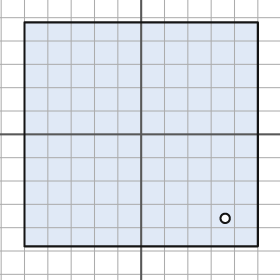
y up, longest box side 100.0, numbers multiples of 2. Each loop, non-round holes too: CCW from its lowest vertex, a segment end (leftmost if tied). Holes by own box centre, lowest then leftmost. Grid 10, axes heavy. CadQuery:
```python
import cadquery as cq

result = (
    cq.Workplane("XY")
    .moveTo(-50.0, -48.0)
    .lineTo(50.0, -48.0)
    .lineTo(50.0, 48.0)
    .lineTo(-50.0, 48.0)
    .close()
    .moveTo(36.0, -36.0)
    .circle(2.0)
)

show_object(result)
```